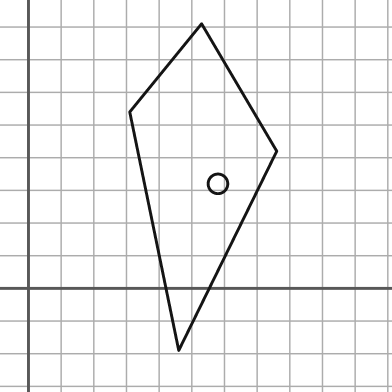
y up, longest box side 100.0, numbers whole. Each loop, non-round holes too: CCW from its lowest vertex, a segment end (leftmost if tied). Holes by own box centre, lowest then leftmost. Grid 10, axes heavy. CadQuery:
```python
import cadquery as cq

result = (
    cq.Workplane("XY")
    .moveTo(46.0, -19.0)
    .lineTo(76.0, 42.0)
    .lineTo(53.0, 81.0)
    .lineTo(31.0, 54.0)
    .close()
    .moveTo(58.0, 32.0)
    .circle(3.0)
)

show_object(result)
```